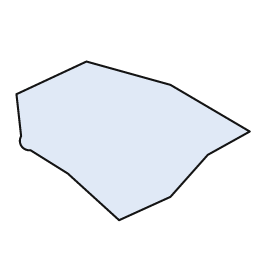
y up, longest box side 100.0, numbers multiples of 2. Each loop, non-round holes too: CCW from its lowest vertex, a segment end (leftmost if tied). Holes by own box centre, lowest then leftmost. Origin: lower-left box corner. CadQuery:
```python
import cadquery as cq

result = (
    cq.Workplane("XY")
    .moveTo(44.0, 0.0)
    .lineTo(66.0, 10.0)
    .lineTo(82.0, 28.0)
    .lineTo(100.0, 38.0)
    .lineTo(66.0, 58.0)
    .lineTo(30.0, 68.0)
    .lineTo(0.0, 54.0)
    .lineTo(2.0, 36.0)
    .threePointArc((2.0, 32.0), (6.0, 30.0))
    .lineTo(22.0, 20.0)
    .close()
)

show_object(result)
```